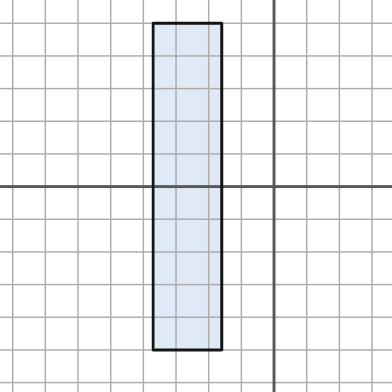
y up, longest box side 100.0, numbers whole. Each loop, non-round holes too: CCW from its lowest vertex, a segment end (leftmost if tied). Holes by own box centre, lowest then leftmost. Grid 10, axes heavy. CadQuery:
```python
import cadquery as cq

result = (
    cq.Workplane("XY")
    .moveTo(-37.0, -50.0)
    .lineTo(-16.0, -50.0)
    .lineTo(-16.0, 50.0)
    .lineTo(-37.0, 50.0)
    .close()
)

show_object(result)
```